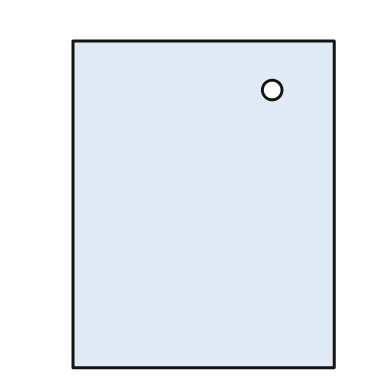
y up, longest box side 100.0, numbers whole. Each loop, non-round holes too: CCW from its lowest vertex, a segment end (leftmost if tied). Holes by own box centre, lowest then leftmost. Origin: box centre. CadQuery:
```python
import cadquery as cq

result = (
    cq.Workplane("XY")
    .moveTo(-40.0, -50.0)
    .lineTo(40.0, -50.0)
    .lineTo(40.0, 50.0)
    .lineTo(-40.0, 50.0)
    .close()
    .moveTo(21.0, 35.0)
    .circle(3.0)
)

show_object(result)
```